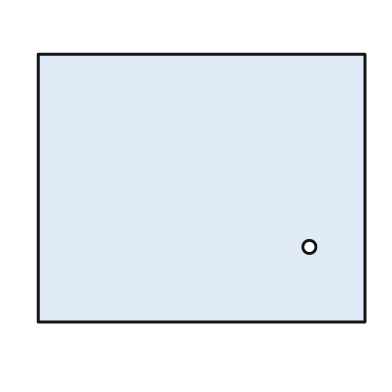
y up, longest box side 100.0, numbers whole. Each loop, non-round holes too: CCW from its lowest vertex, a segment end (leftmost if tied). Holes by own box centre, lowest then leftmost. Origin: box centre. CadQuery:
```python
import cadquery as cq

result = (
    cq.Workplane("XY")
    .moveTo(-50.0, -41.0)
    .lineTo(50.0, -41.0)
    .lineTo(50.0, 41.0)
    .lineTo(-50.0, 41.0)
    .close()
    .moveTo(33.0, -18.0)
    .circle(2.0)
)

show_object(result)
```